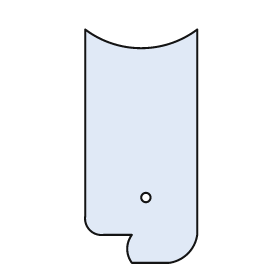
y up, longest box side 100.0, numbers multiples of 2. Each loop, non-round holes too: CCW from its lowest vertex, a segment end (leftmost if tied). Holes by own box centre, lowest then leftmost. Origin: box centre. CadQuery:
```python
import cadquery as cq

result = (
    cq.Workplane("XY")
    .moveTo(-4.0, -50.0)
    .lineTo(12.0, -50.0)
    .threePointArc((20.0, -46.0), (24.0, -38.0))
    .lineTo(24.0, 50.0)
    .threePointArc((0.0, 42.0), (-24.0, 50.0))
    .lineTo(-24.0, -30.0)
    .threePointArc((-22.0, -36.0), (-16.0, -38.0))
    .lineTo(-4.0, -38.0)
    .threePointArc((-6.0, -44.0), (-4.0, -50.0))
    .close()
    .moveTo(2.0, -22.0)
    .circle(2.0)
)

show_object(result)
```